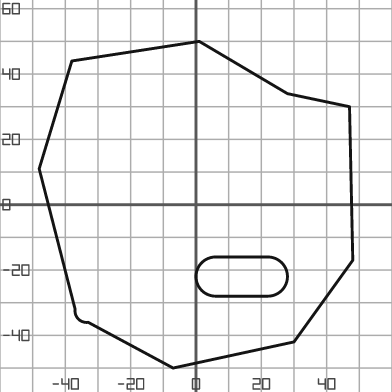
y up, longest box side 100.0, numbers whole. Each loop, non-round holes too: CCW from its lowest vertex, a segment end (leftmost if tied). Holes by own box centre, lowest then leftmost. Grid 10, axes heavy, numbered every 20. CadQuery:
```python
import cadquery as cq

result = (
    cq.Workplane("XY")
    .moveTo(-7.0, -50.0)
    .lineTo(30.0, -42.0)
    .lineTo(48.0, -17.0)
    .lineTo(47.0, 30.0)
    .lineTo(28.0, 34.0)
    .lineTo(1.0, 50.0)
    .lineTo(-38.0, 44.0)
    .lineTo(-48.0, 11.0)
    .lineTo(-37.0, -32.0)
    .threePointArc((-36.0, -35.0), (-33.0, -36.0))
    .close()
    .moveTo(6.0, -28.0)
    .lineTo(22.0, -28.0)
    .threePointArc((28.0, -22.0), (22.0, -16.0))
    .lineTo(6.0, -16.0)
    .threePointArc((0.0, -22.0), (6.0, -28.0))
    .close()
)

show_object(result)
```